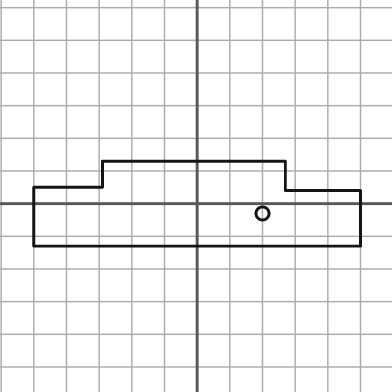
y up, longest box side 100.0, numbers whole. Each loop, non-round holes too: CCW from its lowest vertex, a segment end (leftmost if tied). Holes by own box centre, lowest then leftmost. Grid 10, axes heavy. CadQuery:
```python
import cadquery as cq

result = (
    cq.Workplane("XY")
    .moveTo(-50.0, -13.0)
    .lineTo(50.0, -13.0)
    .lineTo(50.0, 4.0)
    .lineTo(27.0, 4.0)
    .lineTo(27.0, 13.0)
    .lineTo(-29.0, 13.0)
    .lineTo(-29.0, 5.0)
    .lineTo(-50.0, 5.0)
    .close()
    .moveTo(20.0, -3.0)
    .circle(2.0)
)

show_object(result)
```